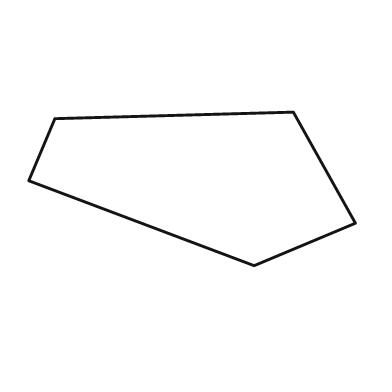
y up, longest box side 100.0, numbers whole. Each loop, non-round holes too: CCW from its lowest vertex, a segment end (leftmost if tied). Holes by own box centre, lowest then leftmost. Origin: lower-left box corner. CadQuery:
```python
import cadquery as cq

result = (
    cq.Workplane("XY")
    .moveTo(69.0, 0.0)
    .lineTo(100.0, 13.0)
    .lineTo(81.0, 47.0)
    .lineTo(8.0, 45.0)
    .lineTo(0.0, 26.0)
    .close()
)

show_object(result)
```